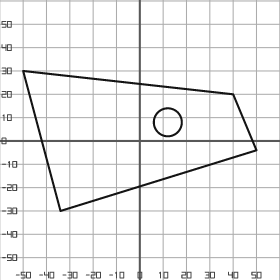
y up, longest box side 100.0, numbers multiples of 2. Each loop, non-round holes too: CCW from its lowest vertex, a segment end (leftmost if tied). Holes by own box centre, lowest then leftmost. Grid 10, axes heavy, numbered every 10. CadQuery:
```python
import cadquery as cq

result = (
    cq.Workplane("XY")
    .moveTo(-34.0, -30.0)
    .lineTo(50.0, -4.0)
    .lineTo(40.0, 20.0)
    .lineTo(-50.0, 30.0)
    .close()
    .moveTo(12.0, 8.0)
    .circle(6.0)
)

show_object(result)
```